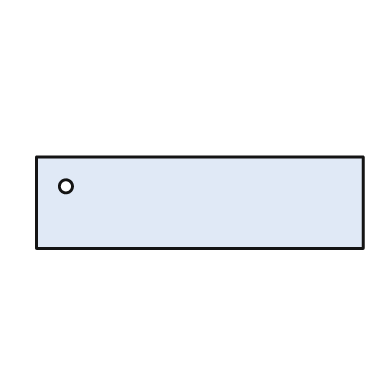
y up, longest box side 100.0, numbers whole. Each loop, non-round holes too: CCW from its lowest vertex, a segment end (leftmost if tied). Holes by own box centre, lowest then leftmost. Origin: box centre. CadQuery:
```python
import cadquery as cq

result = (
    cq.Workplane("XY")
    .moveTo(-50.0, -14.0)
    .lineTo(50.0, -14.0)
    .lineTo(50.0, 14.0)
    .lineTo(-50.0, 14.0)
    .close()
    .moveTo(-41.0, 5.0)
    .circle(2.0)
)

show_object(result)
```